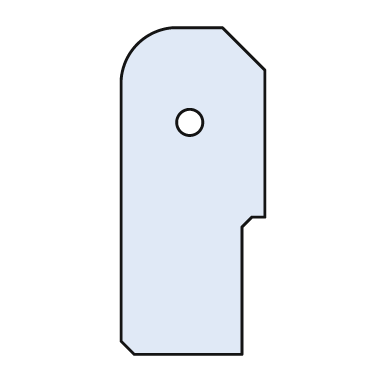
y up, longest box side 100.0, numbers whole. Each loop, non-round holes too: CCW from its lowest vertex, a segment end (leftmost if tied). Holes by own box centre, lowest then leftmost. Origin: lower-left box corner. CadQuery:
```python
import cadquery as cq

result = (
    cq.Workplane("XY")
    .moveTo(4.0, 0.0)
    .lineTo(37.0, 0.0)
    .lineTo(37.0, 39.0)
    .lineTo(40.0, 42.0)
    .lineTo(44.0, 42.0)
    .lineTo(44.0, 87.0)
    .lineTo(31.0, 100.0)
    .lineTo(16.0, 100.0)
    .threePointArc((5.0, 95.0), (0.0, 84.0))
    .lineTo(0.0, 4.0)
    .close()
    .moveTo(21.0, 71.0)
    .circle(4.0)
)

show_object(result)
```